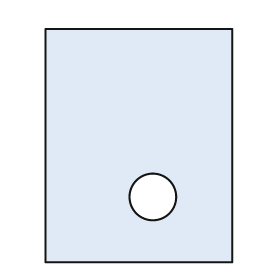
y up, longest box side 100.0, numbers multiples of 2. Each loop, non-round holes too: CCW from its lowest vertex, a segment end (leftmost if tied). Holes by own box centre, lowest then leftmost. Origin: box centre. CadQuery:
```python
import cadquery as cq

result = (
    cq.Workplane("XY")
    .moveTo(-40.0, -50.0)
    .lineTo(40.0, -50.0)
    .lineTo(40.0, 50.0)
    .lineTo(-40.0, 50.0)
    .close()
    .moveTo(6.0, -22.0)
    .circle(10.0)
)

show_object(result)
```